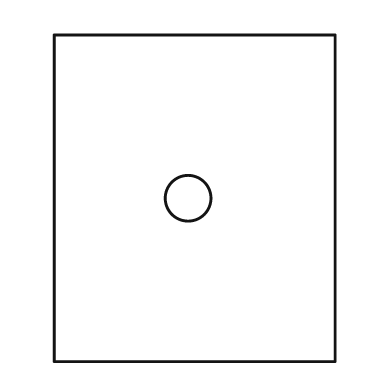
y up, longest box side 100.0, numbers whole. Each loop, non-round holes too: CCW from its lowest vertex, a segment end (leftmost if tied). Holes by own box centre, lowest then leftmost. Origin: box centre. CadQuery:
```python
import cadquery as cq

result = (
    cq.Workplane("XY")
    .moveTo(-43.0, -50.0)
    .lineTo(43.0, -50.0)
    .lineTo(43.0, 50.0)
    .lineTo(-43.0, 50.0)
    .close()
    .moveTo(-2.0, 0.0)
    .circle(7.0)
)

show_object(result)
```